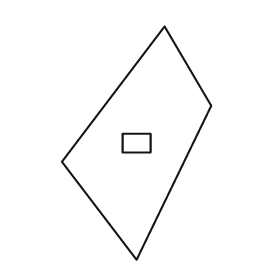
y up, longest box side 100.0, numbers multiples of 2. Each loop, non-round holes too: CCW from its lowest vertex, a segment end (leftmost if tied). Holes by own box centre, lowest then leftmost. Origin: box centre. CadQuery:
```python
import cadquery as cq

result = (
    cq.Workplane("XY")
    .moveTo(0.0, -50.0)
    .lineTo(32.0, 16.0)
    .lineTo(12.0, 50.0)
    .lineTo(-32.0, -8.0)
    .close()
    .moveTo(-6.0, -4.0)
    .lineTo(6.0, -4.0)
    .lineTo(6.0, 4.0)
    .lineTo(-6.0, 4.0)
    .close()
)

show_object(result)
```